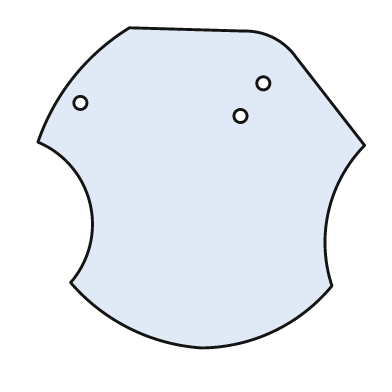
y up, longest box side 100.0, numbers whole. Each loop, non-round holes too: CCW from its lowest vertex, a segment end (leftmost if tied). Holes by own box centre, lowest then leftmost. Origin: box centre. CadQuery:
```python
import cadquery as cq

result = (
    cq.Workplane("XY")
    .moveTo(0.0, -49.0)
    .threePointArc((22.0, -44.0), (40.0, -30.0))
    .threePointArc((39.0, -7.0), (50.0, 13.0))
    .lineTo(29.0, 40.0)
    .threePointArc((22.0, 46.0), (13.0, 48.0))
    .lineTo(-22.0, 49.0)
    .threePointArc((-39.0, 34.0), (-50.0, 14.0))
    .threePointArc((-34.0, -5.0), (-40.0, -29.0))
    .threePointArc((-22.0, -43.0), (0.0, -49.0))
    .close()
    .moveTo(12.0, 22.0)
    .circle(2.0)
    .moveTo(-37.0, 26.0)
    .circle(2.0)
    .moveTo(19.0, 32.0)
    .circle(2.0)
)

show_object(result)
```